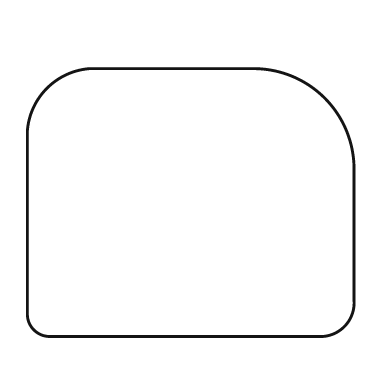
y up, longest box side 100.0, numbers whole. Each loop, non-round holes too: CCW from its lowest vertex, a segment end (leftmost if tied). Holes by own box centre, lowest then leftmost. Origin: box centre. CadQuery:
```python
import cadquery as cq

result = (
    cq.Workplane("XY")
    .moveTo(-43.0, -41.0)
    .lineTo(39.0, -41.0)
    .threePointArc((47.0, -38.0), (50.0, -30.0))
    .lineTo(50.0, 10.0)
    .threePointArc((41.0, 32.0), (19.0, 41.0))
    .lineTo(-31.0, 41.0)
    .threePointArc((-44.0, 35.0), (-50.0, 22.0))
    .lineTo(-50.0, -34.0)
    .threePointArc((-48.0, -39.0), (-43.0, -41.0))
    .close()
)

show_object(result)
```